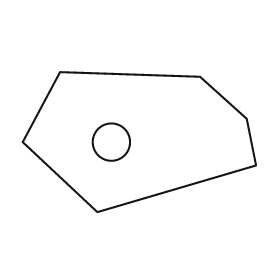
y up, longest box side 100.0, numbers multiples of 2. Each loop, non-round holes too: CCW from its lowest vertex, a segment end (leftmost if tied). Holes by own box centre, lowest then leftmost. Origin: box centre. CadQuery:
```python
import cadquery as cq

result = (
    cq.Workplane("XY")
    .moveTo(-18.0, -30.0)
    .lineTo(50.0, -10.0)
    .lineTo(46.0, 10.0)
    .lineTo(26.0, 28.0)
    .lineTo(-34.0, 30.0)
    .lineTo(-50.0, 0.0)
    .close()
    .moveTo(-12.0, 0.0)
    .circle(8.0)
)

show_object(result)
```